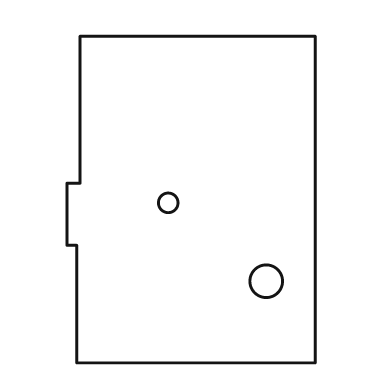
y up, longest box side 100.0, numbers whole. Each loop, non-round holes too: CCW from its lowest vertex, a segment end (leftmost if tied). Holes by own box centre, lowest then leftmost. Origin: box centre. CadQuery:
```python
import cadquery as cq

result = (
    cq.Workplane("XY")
    .moveTo(-35.0, -50.0)
    .lineTo(38.0, -50.0)
    .lineTo(38.0, 50.0)
    .lineTo(-34.0, 50.0)
    .lineTo(-34.0, 5.0)
    .lineTo(-38.0, 5.0)
    .lineTo(-38.0, -14.0)
    .lineTo(-35.0, -14.0)
    .close()
    .moveTo(23.0, -25.0)
    .circle(5.0)
    .moveTo(-7.0, -1.0)
    .circle(3.0)
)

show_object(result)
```